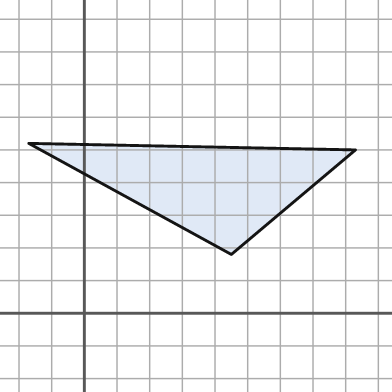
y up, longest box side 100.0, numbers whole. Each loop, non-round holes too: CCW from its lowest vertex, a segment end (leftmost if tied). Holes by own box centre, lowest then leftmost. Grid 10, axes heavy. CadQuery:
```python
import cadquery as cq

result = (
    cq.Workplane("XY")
    .moveTo(45.0, 18.0)
    .lineTo(83.0, 50.0)
    .lineTo(-17.0, 52.0)
    .close()
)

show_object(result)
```